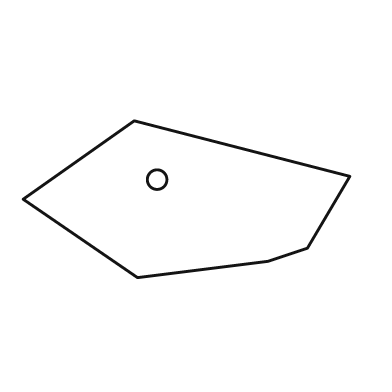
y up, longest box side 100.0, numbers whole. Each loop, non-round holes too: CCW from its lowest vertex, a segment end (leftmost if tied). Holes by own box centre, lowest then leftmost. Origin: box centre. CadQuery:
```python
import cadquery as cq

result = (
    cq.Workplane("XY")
    .moveTo(-15.0, -24.0)
    .lineTo(25.0, -19.0)
    .lineTo(37.0, -15.0)
    .lineTo(50.0, 7.0)
    .lineTo(-16.0, 24.0)
    .lineTo(-50.0, 0.0)
    .close()
    .moveTo(-9.0, 6.0)
    .circle(3.0)
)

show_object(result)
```